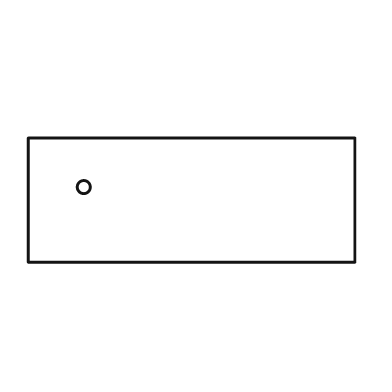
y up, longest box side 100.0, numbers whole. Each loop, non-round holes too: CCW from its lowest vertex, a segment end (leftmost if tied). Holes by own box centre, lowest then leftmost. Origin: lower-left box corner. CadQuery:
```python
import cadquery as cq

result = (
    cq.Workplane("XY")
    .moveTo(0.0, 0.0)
    .lineTo(100.0, 0.0)
    .lineTo(100.0, 38.0)
    .lineTo(0.0, 38.0)
    .close()
    .moveTo(17.0, 23.0)
    .circle(2.0)
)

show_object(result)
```